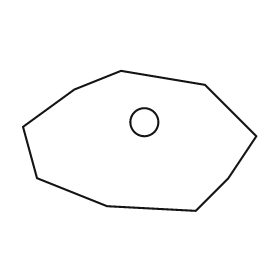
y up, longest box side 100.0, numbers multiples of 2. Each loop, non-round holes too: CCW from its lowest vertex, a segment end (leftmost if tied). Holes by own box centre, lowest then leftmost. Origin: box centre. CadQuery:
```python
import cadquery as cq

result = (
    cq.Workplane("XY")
    .moveTo(24.0, -30.0)
    .lineTo(38.0, -16.0)
    .lineTo(50.0, 2.0)
    .lineTo(28.0, 24.0)
    .lineTo(-8.0, 30.0)
    .lineTo(-28.0, 22.0)
    .lineTo(-50.0, 6.0)
    .lineTo(-44.0, -16.0)
    .lineTo(-14.0, -28.0)
    .close()
    .moveTo(2.0, 8.0)
    .circle(6.0)
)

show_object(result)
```